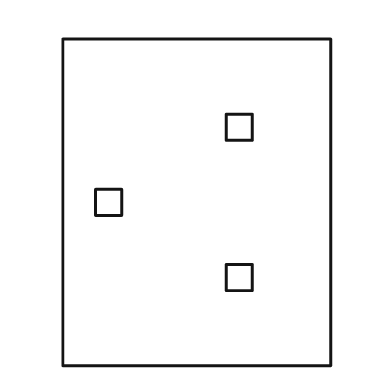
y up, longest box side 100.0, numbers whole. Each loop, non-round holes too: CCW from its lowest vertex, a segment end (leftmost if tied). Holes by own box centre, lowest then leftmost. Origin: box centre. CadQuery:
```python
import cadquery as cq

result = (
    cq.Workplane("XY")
    .moveTo(-41.0, -50.0)
    .lineTo(41.0, -50.0)
    .lineTo(41.0, 50.0)
    .lineTo(-41.0, 50.0)
    .close()
    .moveTo(9.0, -27.0)
    .lineTo(17.0, -27.0)
    .lineTo(17.0, -19.0)
    .lineTo(9.0, -19.0)
    .close()
    .moveTo(-31.0, -4.0)
    .lineTo(-23.0, -4.0)
    .lineTo(-23.0, 4.0)
    .lineTo(-31.0, 4.0)
    .close()
    .moveTo(9.0, 19.0)
    .lineTo(17.0, 19.0)
    .lineTo(17.0, 27.0)
    .lineTo(9.0, 27.0)
    .close()
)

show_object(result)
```